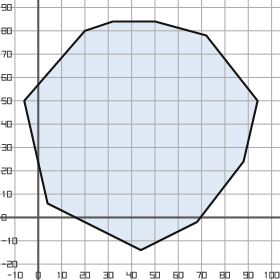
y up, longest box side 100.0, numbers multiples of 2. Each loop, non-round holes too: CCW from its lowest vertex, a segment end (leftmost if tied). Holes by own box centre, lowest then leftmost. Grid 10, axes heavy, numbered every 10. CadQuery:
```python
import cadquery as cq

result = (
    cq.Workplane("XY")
    .moveTo(44.0, -14.0)
    .lineTo(68.0, -2.0)
    .lineTo(88.0, 24.0)
    .lineTo(94.0, 50.0)
    .lineTo(72.0, 78.0)
    .lineTo(50.0, 84.0)
    .lineTo(32.0, 84.0)
    .lineTo(20.0, 80.0)
    .lineTo(-6.0, 50.0)
    .lineTo(4.0, 6.0)
    .close()
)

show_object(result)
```